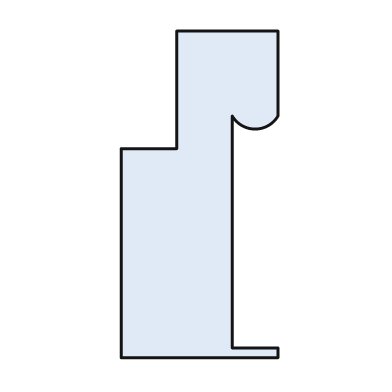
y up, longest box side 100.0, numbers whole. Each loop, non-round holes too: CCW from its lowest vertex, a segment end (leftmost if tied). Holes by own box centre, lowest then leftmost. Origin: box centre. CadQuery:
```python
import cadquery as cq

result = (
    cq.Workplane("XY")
    .moveTo(-24.0, -50.0)
    .lineTo(24.0, -50.0)
    .lineTo(24.0, -47.0)
    .lineTo(10.0, -47.0)
    .lineTo(10.0, 24.0)
    .threePointArc((17.0, 20.0), (24.0, 24.0))
    .lineTo(24.0, 50.0)
    .lineTo(-7.0, 50.0)
    .lineTo(-7.0, 14.0)
    .lineTo(-24.0, 14.0)
    .close()
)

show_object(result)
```